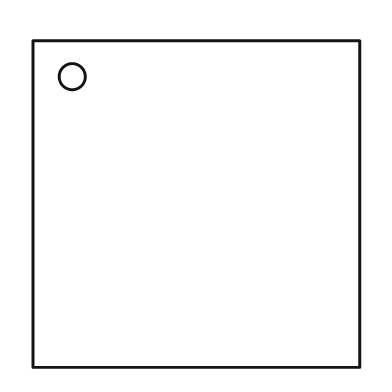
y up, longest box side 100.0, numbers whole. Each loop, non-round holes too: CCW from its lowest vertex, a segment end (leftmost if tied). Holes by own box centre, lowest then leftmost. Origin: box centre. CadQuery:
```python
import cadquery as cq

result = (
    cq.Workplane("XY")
    .moveTo(-50.0, -50.0)
    .lineTo(50.0, -50.0)
    .lineTo(50.0, 50.0)
    .lineTo(-50.0, 50.0)
    .close()
    .moveTo(-38.0, 39.0)
    .circle(4.0)
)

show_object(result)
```